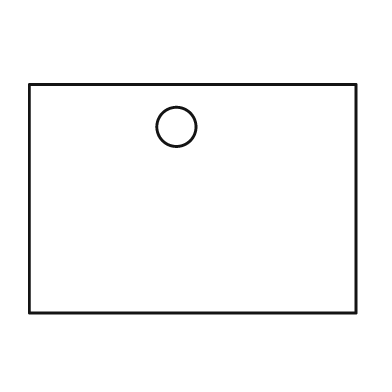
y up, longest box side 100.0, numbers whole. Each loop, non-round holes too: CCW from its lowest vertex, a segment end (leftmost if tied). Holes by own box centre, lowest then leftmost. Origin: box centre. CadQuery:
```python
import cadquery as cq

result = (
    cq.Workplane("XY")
    .moveTo(-50.0, -35.0)
    .lineTo(50.0, -35.0)
    .lineTo(50.0, 35.0)
    .lineTo(-50.0, 35.0)
    .close()
    .moveTo(-5.0, 22.0)
    .circle(6.0)
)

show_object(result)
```